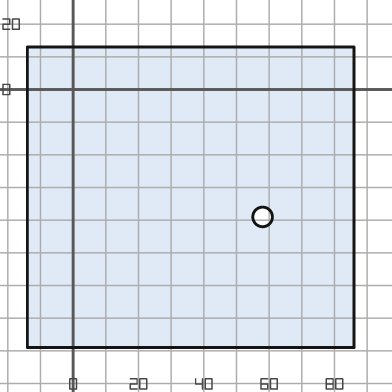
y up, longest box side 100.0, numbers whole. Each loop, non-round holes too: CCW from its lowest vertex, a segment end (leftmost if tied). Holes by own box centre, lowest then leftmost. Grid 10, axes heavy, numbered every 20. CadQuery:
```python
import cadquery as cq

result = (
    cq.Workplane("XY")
    .moveTo(-14.0, -79.0)
    .lineTo(86.0, -79.0)
    .lineTo(86.0, 13.0)
    .lineTo(-14.0, 13.0)
    .close()
    .moveTo(58.0, -39.0)
    .circle(3.0)
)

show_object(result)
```